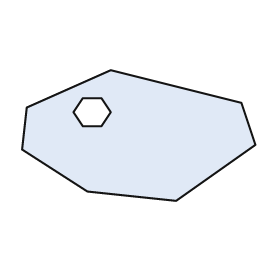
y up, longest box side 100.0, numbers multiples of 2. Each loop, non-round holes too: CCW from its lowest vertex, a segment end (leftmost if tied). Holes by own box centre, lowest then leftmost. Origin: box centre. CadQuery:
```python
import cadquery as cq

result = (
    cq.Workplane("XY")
    .moveTo(16.0, -28.0)
    .lineTo(50.0, -4.0)
    .lineTo(44.0, 14.0)
    .lineTo(-12.0, 28.0)
    .lineTo(-48.0, 12.0)
    .lineTo(-50.0, -6.0)
    .lineTo(-22.0, -24.0)
    .close()
    .moveTo(-24.0, 4.0)
    .lineTo(-16.0, 4.0)
    .lineTo(-12.0, 10.0)
    .lineTo(-16.0, 16.0)
    .lineTo(-24.0, 16.0)
    .lineTo(-28.0, 10.0)
    .close()
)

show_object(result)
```